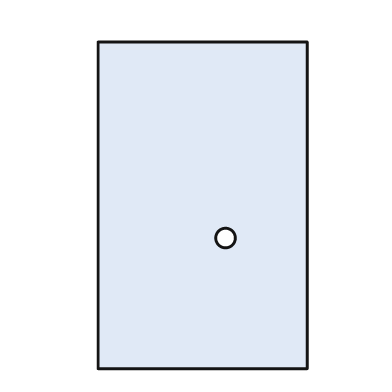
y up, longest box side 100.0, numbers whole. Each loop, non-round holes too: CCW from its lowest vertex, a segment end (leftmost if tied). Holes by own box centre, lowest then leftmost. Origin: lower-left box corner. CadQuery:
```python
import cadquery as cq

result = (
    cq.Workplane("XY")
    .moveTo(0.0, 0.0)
    .lineTo(64.0, 0.0)
    .lineTo(64.0, 100.0)
    .lineTo(0.0, 100.0)
    .close()
    .moveTo(39.0, 40.0)
    .circle(3.0)
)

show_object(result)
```